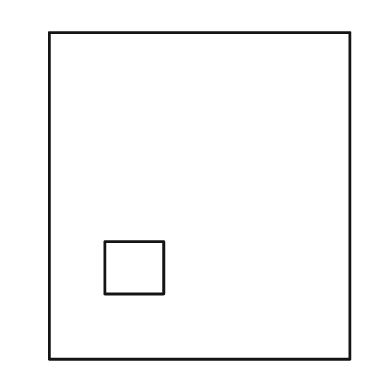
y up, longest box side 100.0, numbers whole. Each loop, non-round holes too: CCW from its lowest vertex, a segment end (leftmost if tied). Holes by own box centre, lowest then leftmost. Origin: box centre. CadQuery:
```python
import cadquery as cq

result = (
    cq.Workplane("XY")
    .moveTo(-46.0, -50.0)
    .lineTo(46.0, -50.0)
    .lineTo(46.0, 50.0)
    .lineTo(-46.0, 50.0)
    .close()
    .moveTo(-29.0, -30.0)
    .lineTo(-11.0, -30.0)
    .lineTo(-11.0, -14.0)
    .lineTo(-29.0, -14.0)
    .close()
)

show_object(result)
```